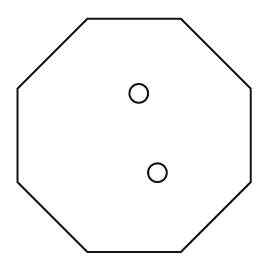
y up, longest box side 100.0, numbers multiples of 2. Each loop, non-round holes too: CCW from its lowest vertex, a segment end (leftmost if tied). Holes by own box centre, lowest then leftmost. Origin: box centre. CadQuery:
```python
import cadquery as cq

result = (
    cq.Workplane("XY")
    .moveTo(-20.0, -50.0)
    .lineTo(20.0, -50.0)
    .lineTo(50.0, -20.0)
    .lineTo(50.0, 20.0)
    .lineTo(20.0, 50.0)
    .lineTo(-20.0, 50.0)
    .lineTo(-50.0, 20.0)
    .lineTo(-50.0, -20.0)
    .close()
    .moveTo(10.0, -16.0)
    .circle(4.0)
    .moveTo(2.0, 18.0)
    .circle(4.0)
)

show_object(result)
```